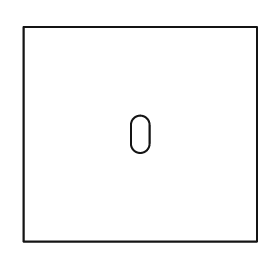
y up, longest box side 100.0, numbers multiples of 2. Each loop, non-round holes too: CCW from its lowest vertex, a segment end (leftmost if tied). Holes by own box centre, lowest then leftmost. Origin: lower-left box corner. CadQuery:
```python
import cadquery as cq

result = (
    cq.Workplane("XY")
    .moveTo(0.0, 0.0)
    .lineTo(100.0, 0.0)
    .lineTo(100.0, 92.0)
    .lineTo(0.0, 92.0)
    .close()
    .moveTo(46.0, 42.0)
    .threePointArc((50.0, 38.0), (54.0, 42.0))
    .lineTo(54.0, 50.0)
    .threePointArc((50.0, 54.0), (46.0, 50.0))
    .close()
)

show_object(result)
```